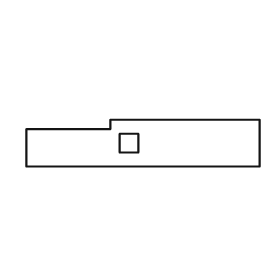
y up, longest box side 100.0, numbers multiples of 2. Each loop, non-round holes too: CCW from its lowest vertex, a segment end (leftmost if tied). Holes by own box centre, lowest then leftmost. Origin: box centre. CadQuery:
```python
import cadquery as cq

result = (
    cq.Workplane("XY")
    .moveTo(-50.0, -10.0)
    .lineTo(50.0, -10.0)
    .lineTo(50.0, 10.0)
    .lineTo(-14.0, 10.0)
    .lineTo(-14.0, 6.0)
    .lineTo(-50.0, 6.0)
    .close()
    .moveTo(-10.0, -4.0)
    .lineTo(-2.0, -4.0)
    .lineTo(-2.0, 4.0)
    .lineTo(-10.0, 4.0)
    .close()
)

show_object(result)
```